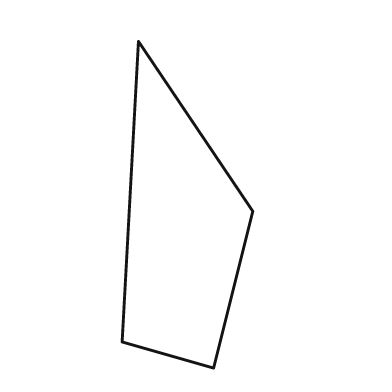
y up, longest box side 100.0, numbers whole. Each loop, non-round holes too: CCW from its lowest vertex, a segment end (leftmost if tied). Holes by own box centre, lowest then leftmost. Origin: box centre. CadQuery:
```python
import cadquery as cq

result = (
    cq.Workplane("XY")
    .moveTo(8.0, -50.0)
    .lineTo(20.0, -2.0)
    .lineTo(-15.0, 50.0)
    .lineTo(-20.0, -42.0)
    .close()
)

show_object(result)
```